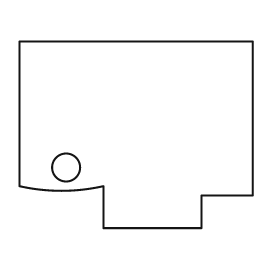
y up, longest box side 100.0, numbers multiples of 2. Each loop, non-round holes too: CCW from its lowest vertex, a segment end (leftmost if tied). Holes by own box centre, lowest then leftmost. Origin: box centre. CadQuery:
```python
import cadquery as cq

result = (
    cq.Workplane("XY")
    .moveTo(-14.0, -40.0)
    .lineTo(28.0, -40.0)
    .lineTo(28.0, -26.0)
    .lineTo(50.0, -26.0)
    .lineTo(50.0, 40.0)
    .lineTo(-50.0, 40.0)
    .lineTo(-50.0, -22.0)
    .threePointArc((-32.0, -24.0), (-14.0, -22.0))
    .close()
    .moveTo(-30.0, -14.0)
    .circle(6.0)
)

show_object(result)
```